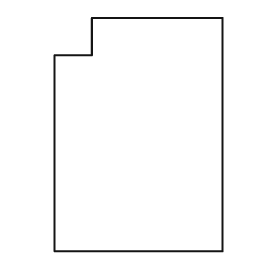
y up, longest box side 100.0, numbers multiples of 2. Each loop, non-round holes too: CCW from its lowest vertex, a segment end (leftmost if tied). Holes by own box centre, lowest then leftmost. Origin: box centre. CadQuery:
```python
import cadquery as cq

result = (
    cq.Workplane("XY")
    .moveTo(-36.0, -50.0)
    .lineTo(36.0, -50.0)
    .lineTo(36.0, 50.0)
    .lineTo(-20.0, 50.0)
    .lineTo(-20.0, 34.0)
    .lineTo(-36.0, 34.0)
    .close()
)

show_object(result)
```